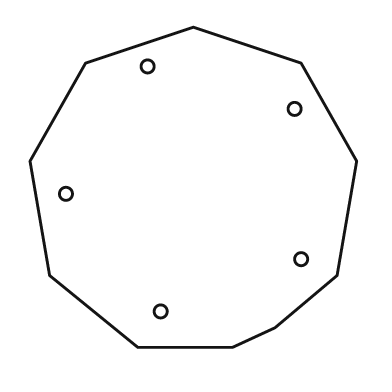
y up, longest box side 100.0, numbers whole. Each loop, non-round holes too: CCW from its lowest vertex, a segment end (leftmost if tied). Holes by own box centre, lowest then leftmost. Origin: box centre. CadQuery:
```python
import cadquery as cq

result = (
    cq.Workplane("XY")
    .moveTo(-17.0, -49.0)
    .lineTo(12.0, -49.0)
    .lineTo(25.0, -43.0)
    .lineTo(44.0, -27.0)
    .lineTo(50.0, 8.0)
    .lineTo(33.0, 38.0)
    .lineTo(0.0, 49.0)
    .lineTo(-33.0, 38.0)
    .lineTo(-50.0, 8.0)
    .lineTo(-44.0, -27.0)
    .close()
    .moveTo(-10.0, -38.0)
    .circle(2.0)
    .moveTo(33.0, -22.0)
    .circle(2.0)
    .moveTo(-39.0, -2.0)
    .circle(2.0)
    .moveTo(31.0, 24.0)
    .circle(2.0)
    .moveTo(-14.0, 37.0)
    .circle(2.0)
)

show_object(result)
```